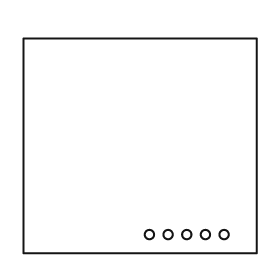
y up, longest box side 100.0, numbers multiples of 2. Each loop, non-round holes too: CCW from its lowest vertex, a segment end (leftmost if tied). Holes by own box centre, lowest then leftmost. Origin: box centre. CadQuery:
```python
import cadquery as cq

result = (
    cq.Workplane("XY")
    .moveTo(-50.0, -46.0)
    .lineTo(50.0, -46.0)
    .lineTo(50.0, 46.0)
    .lineTo(-50.0, 46.0)
    .close()
    .moveTo(4.0, -38.0)
    .circle(2.0)
    .moveTo(12.0, -38.0)
    .circle(2.0)
    .moveTo(20.0, -38.0)
    .circle(2.0)
    .moveTo(28.0, -38.0)
    .circle(2.0)
    .moveTo(36.0, -38.0)
    .circle(2.0)
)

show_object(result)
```